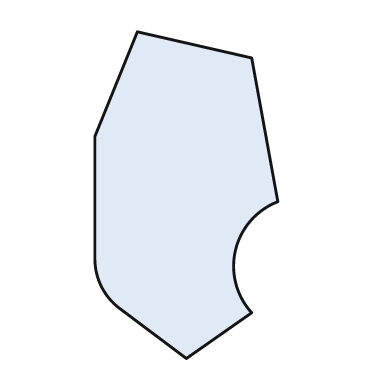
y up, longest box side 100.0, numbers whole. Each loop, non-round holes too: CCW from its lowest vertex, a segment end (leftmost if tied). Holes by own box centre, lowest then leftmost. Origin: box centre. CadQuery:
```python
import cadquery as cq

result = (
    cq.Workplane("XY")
    .moveTo(0.0, -50.0)
    .lineTo(20.0, -36.0)
    .threePointArc((15.0, -17.0), (28.0, -2.0))
    .lineTo(20.0, 42.0)
    .lineTo(-15.0, 50.0)
    .lineTo(-28.0, 18.0)
    .lineTo(-28.0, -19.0)
    .threePointArc((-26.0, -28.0), (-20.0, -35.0))
    .close()
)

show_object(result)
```